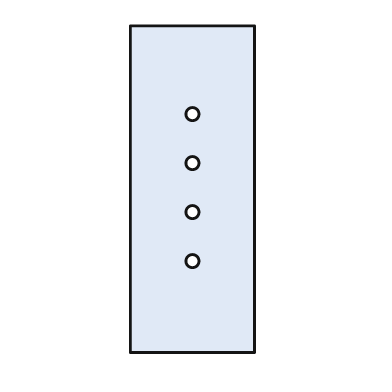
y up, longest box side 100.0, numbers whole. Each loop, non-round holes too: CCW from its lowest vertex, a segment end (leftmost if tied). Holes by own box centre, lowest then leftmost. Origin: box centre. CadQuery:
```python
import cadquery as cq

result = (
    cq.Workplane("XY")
    .moveTo(-19.0, -50.0)
    .lineTo(19.0, -50.0)
    .lineTo(19.0, 50.0)
    .lineTo(-19.0, 50.0)
    .close()
    .moveTo(0.0, -22.0)
    .circle(2.0)
    .moveTo(0.0, -7.0)
    .circle(2.0)
    .moveTo(0.0, 8.0)
    .circle(2.0)
    .moveTo(0.0, 23.0)
    .circle(2.0)
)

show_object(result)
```